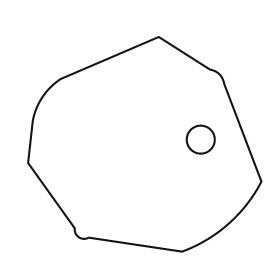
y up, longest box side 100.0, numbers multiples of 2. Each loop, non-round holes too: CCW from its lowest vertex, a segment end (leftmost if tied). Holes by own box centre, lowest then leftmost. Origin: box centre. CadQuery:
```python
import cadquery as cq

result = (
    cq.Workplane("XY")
    .moveTo(16.0, -46.0)
    .threePointArc((36.0, -34.0), (50.0, -16.0))
    .lineTo(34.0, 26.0)
    .threePointArc((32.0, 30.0), (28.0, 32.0))
    .lineTo(6.0, 46.0)
    .lineTo(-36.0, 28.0)
    .threePointArc((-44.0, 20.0), (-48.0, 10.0))
    .lineTo(-50.0, -8.0)
    .lineTo(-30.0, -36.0)
    .threePointArc((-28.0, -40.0), (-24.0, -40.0))
    .close()
    .moveTo(24.0, 2.0)
    .circle(6.0)
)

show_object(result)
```